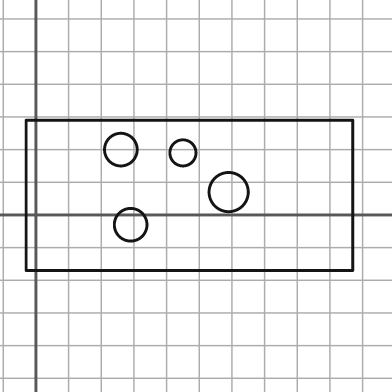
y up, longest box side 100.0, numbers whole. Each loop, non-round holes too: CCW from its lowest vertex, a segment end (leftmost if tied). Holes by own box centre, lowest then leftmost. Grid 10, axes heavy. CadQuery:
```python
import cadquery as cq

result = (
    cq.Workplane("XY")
    .moveTo(-3.0, -17.0)
    .lineTo(97.0, -17.0)
    .lineTo(97.0, 29.0)
    .lineTo(-3.0, 29.0)
    .close()
    .moveTo(29.0, -3.0)
    .circle(5.0)
    .moveTo(59.0, 7.0)
    .circle(6.0)
    .moveTo(45.0, 19.0)
    .circle(4.0)
    .moveTo(26.0, 20.0)
    .circle(5.0)
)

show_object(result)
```